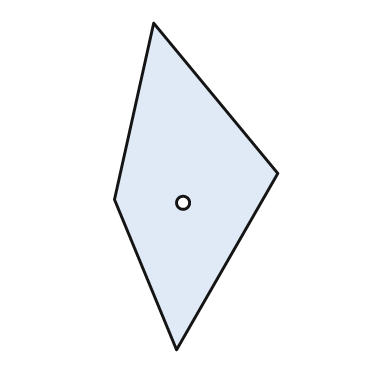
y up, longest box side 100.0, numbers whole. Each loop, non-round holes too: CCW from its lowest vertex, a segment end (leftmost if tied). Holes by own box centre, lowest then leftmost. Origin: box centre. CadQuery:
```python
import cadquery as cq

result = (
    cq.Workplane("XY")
    .moveTo(-6.0, -50.0)
    .lineTo(25.0, 4.0)
    .lineTo(-13.0, 50.0)
    .lineTo(-25.0, -4.0)
    .close()
    .moveTo(-4.0, -5.0)
    .circle(2.0)
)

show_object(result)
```